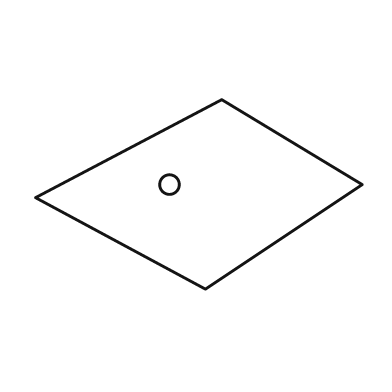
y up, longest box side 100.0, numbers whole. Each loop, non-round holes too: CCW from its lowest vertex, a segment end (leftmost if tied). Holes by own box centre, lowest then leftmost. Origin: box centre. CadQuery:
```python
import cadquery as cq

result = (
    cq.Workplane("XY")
    .moveTo(2.0, -29.0)
    .lineTo(50.0, 3.0)
    .lineTo(7.0, 29.0)
    .lineTo(-50.0, -1.0)
    .close()
    .moveTo(-9.0, 3.0)
    .circle(3.0)
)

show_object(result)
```